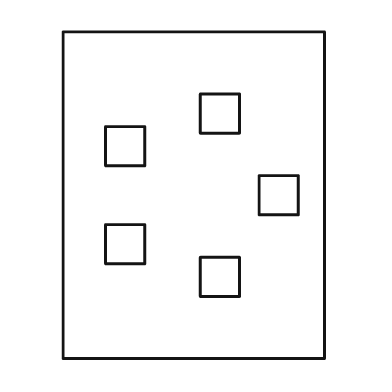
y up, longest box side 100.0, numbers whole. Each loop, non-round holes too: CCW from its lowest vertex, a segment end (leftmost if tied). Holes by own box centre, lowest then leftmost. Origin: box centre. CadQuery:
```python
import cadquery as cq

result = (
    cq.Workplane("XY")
    .moveTo(-40.0, -50.0)
    .lineTo(40.0, -50.0)
    .lineTo(40.0, 50.0)
    .lineTo(-40.0, 50.0)
    .close()
    .moveTo(2.0, -31.0)
    .lineTo(14.0, -31.0)
    .lineTo(14.0, -19.0)
    .lineTo(2.0, -19.0)
    .close()
    .moveTo(-27.0, -21.0)
    .lineTo(-15.0, -21.0)
    .lineTo(-15.0, -9.0)
    .lineTo(-27.0, -9.0)
    .close()
    .moveTo(20.0, -6.0)
    .lineTo(32.0, -6.0)
    .lineTo(32.0, 6.0)
    .lineTo(20.0, 6.0)
    .close()
    .moveTo(-27.0, 9.0)
    .lineTo(-15.0, 9.0)
    .lineTo(-15.0, 21.0)
    .lineTo(-27.0, 21.0)
    .close()
    .moveTo(2.0, 19.0)
    .lineTo(14.0, 19.0)
    .lineTo(14.0, 31.0)
    .lineTo(2.0, 31.0)
    .close()
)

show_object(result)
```